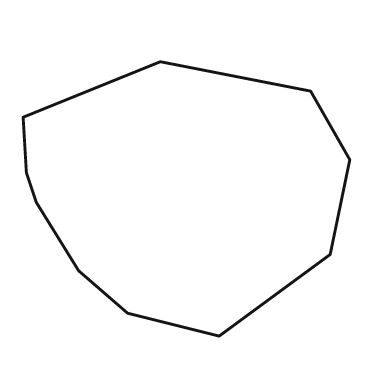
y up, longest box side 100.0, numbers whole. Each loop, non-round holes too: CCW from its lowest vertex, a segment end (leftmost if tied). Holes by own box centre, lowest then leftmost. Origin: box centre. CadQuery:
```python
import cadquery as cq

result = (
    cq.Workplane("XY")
    .moveTo(10.0, -42.0)
    .lineTo(44.0, -17.0)
    .lineTo(50.0, 12.0)
    .lineTo(38.0, 33.0)
    .lineTo(-8.0, 42.0)
    .lineTo(-50.0, 25.0)
    .lineTo(-49.0, 8.0)
    .lineTo(-46.0, -1.0)
    .lineTo(-33.0, -22.0)
    .lineTo(-18.0, -35.0)
    .close()
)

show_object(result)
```